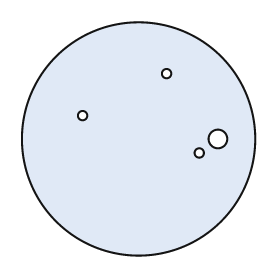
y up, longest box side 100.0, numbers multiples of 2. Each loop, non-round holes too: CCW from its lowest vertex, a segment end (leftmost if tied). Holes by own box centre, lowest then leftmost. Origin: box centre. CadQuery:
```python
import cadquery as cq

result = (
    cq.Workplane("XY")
    .moveTo(0.0, 0.0)
    .circle(50.0)
    .moveTo(26.0, -6.0)
    .circle(2.0)
    .moveTo(34.0, 0.0)
    .circle(4.0)
    .moveTo(-24.0, 10.0)
    .circle(2.0)
    .moveTo(12.0, 28.0)
    .circle(2.0)
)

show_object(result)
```